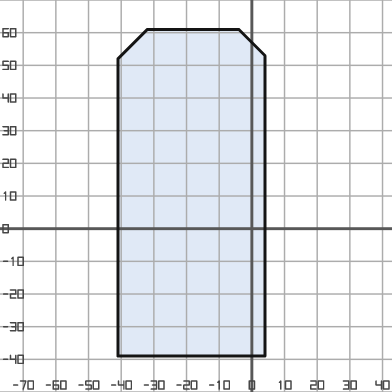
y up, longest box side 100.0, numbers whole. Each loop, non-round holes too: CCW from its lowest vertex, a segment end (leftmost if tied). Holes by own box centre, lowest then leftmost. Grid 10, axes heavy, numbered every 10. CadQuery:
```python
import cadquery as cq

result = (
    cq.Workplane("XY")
    .moveTo(-41.0, -39.0)
    .lineTo(4.0, -39.0)
    .lineTo(4.0, 53.0)
    .lineTo(-4.0, 61.0)
    .lineTo(-32.0, 61.0)
    .lineTo(-41.0, 52.0)
    .close()
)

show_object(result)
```